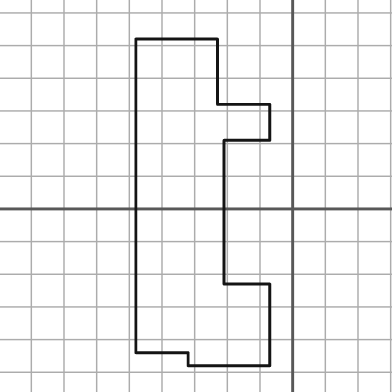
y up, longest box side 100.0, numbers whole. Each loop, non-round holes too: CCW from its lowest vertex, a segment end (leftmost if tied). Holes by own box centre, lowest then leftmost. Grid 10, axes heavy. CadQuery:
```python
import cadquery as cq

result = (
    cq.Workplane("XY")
    .moveTo(-32.0, -48.0)
    .lineTo(-7.0, -48.0)
    .lineTo(-7.0, -23.0)
    .lineTo(-21.0, -23.0)
    .lineTo(-21.0, 21.0)
    .lineTo(-7.0, 21.0)
    .lineTo(-7.0, 32.0)
    .lineTo(-23.0, 32.0)
    .lineTo(-23.0, 52.0)
    .lineTo(-48.0, 52.0)
    .lineTo(-48.0, -44.0)
    .lineTo(-32.0, -44.0)
    .close()
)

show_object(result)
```